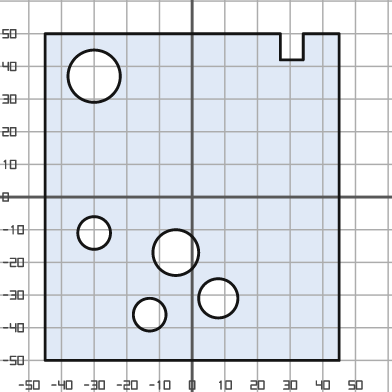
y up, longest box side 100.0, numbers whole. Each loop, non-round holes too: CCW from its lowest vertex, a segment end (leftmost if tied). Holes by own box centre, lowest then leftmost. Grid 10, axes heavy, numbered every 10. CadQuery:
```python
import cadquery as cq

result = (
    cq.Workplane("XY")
    .moveTo(-45.0, -50.0)
    .lineTo(45.0, -50.0)
    .lineTo(45.0, 50.0)
    .lineTo(34.0, 50.0)
    .lineTo(34.0, 42.0)
    .lineTo(27.0, 42.0)
    .lineTo(27.0, 50.0)
    .lineTo(-45.0, 50.0)
    .close()
    .moveTo(-13.0, -36.0)
    .circle(5.0)
    .moveTo(8.0, -31.0)
    .circle(6.0)
    .moveTo(-5.0, -17.0)
    .circle(7.0)
    .moveTo(-30.0, -11.0)
    .circle(5.0)
    .moveTo(-30.0, 37.0)
    .circle(8.0)
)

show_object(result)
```